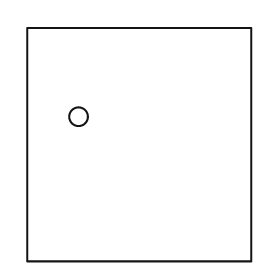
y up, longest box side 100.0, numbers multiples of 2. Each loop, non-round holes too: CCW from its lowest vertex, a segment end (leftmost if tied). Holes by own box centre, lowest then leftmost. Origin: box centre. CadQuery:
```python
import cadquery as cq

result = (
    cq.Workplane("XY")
    .moveTo(-48.0, -50.0)
    .lineTo(48.0, -50.0)
    .lineTo(48.0, 50.0)
    .lineTo(-48.0, 50.0)
    .close()
    .moveTo(-26.0, 12.0)
    .circle(4.0)
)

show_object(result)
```